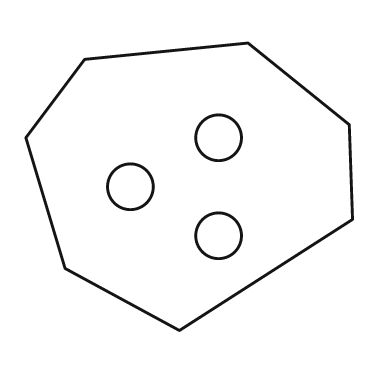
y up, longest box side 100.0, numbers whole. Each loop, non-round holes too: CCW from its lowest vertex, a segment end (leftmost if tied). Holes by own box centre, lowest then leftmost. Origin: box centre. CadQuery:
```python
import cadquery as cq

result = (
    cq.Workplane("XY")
    .moveTo(-3.0, -44.0)
    .lineTo(50.0, -10.0)
    .lineTo(49.0, 19.0)
    .lineTo(18.0, 44.0)
    .lineTo(-32.0, 39.0)
    .lineTo(-50.0, 15.0)
    .lineTo(-38.0, -25.0)
    .close()
    .moveTo(9.0, -15.0)
    .circle(7.0)
    .moveTo(-18.0, 0.0)
    .circle(7.0)
    .moveTo(9.0, 15.0)
    .circle(7.0)
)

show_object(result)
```